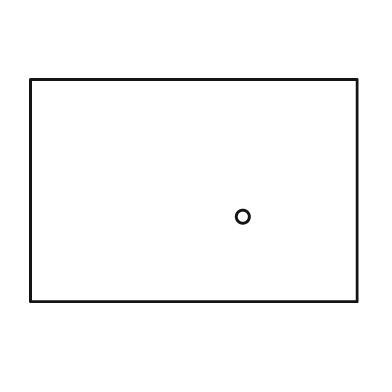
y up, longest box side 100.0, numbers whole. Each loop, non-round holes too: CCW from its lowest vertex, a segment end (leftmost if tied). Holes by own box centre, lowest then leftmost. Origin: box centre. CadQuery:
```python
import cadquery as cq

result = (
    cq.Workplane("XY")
    .moveTo(-50.0, -34.0)
    .lineTo(50.0, -34.0)
    .lineTo(50.0, 34.0)
    .lineTo(-50.0, 34.0)
    .close()
    .moveTo(15.0, -8.0)
    .circle(2.0)
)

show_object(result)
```